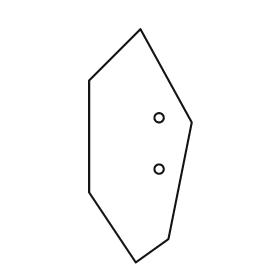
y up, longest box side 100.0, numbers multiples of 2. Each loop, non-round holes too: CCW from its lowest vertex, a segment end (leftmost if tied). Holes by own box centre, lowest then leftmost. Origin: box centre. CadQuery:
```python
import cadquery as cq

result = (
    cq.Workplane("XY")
    .moveTo(-2.0, -50.0)
    .lineTo(12.0, -40.0)
    .lineTo(22.0, 10.0)
    .lineTo(0.0, 50.0)
    .lineTo(-22.0, 28.0)
    .lineTo(-22.0, -20.0)
    .close()
    .moveTo(8.0, -10.0)
    .circle(2.0)
    .moveTo(8.0, 12.0)
    .circle(2.0)
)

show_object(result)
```